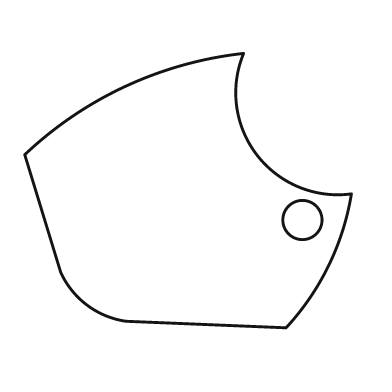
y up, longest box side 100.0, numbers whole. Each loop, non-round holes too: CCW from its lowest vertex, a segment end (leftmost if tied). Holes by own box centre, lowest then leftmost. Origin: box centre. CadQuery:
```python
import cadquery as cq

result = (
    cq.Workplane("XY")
    .moveTo(30.0, -42.0)
    .threePointArc((43.0, -23.0), (50.0, -1.0))
    .threePointArc((21.0, 11.0), (17.0, 42.0))
    .threePointArc((-19.0, 32.0), (-50.0, 11.0))
    .lineTo(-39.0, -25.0)
    .threePointArc((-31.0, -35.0), (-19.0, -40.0))
    .close()
    .moveTo(35.0, -9.0)
    .circle(6.0)
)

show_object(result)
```